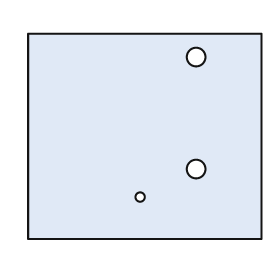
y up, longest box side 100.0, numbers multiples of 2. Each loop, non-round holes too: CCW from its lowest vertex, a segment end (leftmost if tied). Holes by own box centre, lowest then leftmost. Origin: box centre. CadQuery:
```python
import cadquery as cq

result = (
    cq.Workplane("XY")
    .moveTo(-50.0, -44.0)
    .lineTo(50.0, -44.0)
    .lineTo(50.0, 44.0)
    .lineTo(-50.0, 44.0)
    .close()
    .moveTo(-2.0, -26.0)
    .circle(2.0)
    .moveTo(22.0, -14.0)
    .circle(4.0)
    .moveTo(22.0, 34.0)
    .circle(4.0)
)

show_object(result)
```